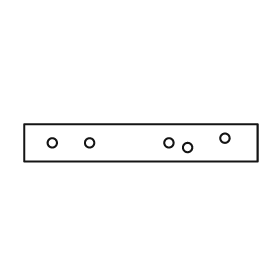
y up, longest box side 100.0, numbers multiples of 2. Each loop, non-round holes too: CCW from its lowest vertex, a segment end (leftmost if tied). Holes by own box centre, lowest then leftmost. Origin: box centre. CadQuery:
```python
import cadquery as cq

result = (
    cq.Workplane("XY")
    .moveTo(-50.0, -8.0)
    .lineTo(50.0, -8.0)
    .lineTo(50.0, 8.0)
    .lineTo(-50.0, 8.0)
    .close()
    .moveTo(20.0, -2.0)
    .circle(2.0)
    .moveTo(-38.0, 0.0)
    .circle(2.0)
    .moveTo(-22.0, 0.0)
    .circle(2.0)
    .moveTo(12.0, 0.0)
    .circle(2.0)
    .moveTo(36.0, 2.0)
    .circle(2.0)
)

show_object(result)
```